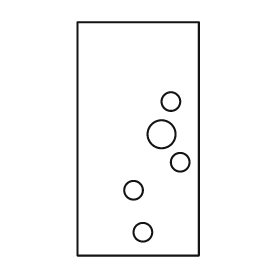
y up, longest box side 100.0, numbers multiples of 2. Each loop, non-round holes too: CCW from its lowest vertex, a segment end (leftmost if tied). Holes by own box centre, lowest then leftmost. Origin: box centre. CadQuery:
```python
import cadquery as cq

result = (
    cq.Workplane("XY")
    .moveTo(-26.0, -50.0)
    .lineTo(26.0, -50.0)
    .lineTo(26.0, 50.0)
    .lineTo(-26.0, 50.0)
    .close()
    .moveTo(2.0, -40.0)
    .circle(4.0)
    .moveTo(-2.0, -22.0)
    .circle(4.0)
    .moveTo(18.0, -10.0)
    .circle(4.0)
    .moveTo(10.0, 2.0)
    .circle(6.0)
    .moveTo(14.0, 16.0)
    .circle(4.0)
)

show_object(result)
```